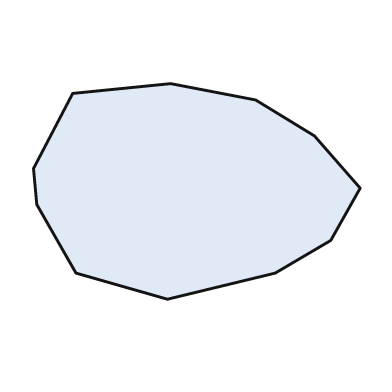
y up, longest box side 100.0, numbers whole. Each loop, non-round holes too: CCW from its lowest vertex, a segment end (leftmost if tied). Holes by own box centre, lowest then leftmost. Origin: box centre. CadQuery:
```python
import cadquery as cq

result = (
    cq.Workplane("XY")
    .moveTo(-9.0, -33.0)
    .lineTo(24.0, -25.0)
    .lineTo(41.0, -15.0)
    .lineTo(50.0, 1.0)
    .lineTo(36.0, 17.0)
    .lineTo(18.0, 28.0)
    .lineTo(-8.0, 33.0)
    .lineTo(-38.0, 30.0)
    .lineTo(-50.0, 7.0)
    .lineTo(-49.0, -4.0)
    .lineTo(-37.0, -25.0)
    .close()
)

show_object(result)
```